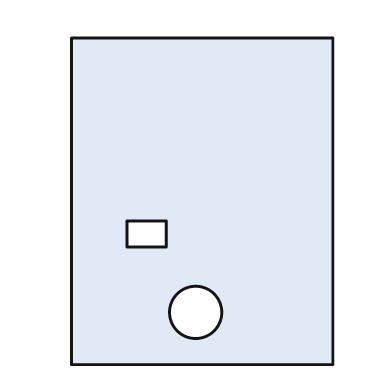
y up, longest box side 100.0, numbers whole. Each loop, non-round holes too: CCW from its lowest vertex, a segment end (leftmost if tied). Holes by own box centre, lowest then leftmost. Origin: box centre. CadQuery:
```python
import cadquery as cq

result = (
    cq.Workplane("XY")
    .moveTo(-40.0, -50.0)
    .lineTo(40.0, -50.0)
    .lineTo(40.0, 50.0)
    .lineTo(-40.0, 50.0)
    .close()
    .moveTo(-2.0, -34.0)
    .circle(8.0)
    .moveTo(-23.0, -14.0)
    .lineTo(-11.0, -14.0)
    .lineTo(-11.0, -6.0)
    .lineTo(-23.0, -6.0)
    .close()
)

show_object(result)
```